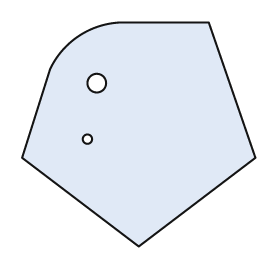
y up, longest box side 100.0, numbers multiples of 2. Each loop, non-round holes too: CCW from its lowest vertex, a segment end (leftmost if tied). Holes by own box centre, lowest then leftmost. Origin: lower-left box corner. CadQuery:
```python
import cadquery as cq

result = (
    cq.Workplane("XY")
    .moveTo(50.0, 0.0)
    .lineTo(100.0, 38.0)
    .lineTo(80.0, 96.0)
    .lineTo(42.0, 96.0)
    .threePointArc((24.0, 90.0), (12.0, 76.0))
    .lineTo(0.0, 38.0)
    .close()
    .moveTo(28.0, 46.0)
    .circle(2.0)
    .moveTo(32.0, 70.0)
    .circle(4.0)
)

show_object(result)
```